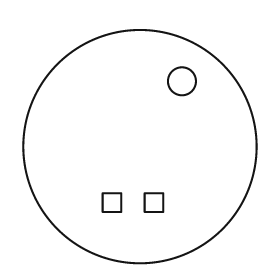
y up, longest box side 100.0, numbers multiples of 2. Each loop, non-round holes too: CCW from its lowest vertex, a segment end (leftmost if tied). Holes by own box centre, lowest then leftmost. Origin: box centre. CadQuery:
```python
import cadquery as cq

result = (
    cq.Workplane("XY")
    .moveTo(0.0, 0.0)
    .circle(50.0)
    .moveTo(-16.0, -28.0)
    .lineTo(-8.0, -28.0)
    .lineTo(-8.0, -20.0)
    .lineTo(-16.0, -20.0)
    .close()
    .moveTo(2.0, -28.0)
    .lineTo(10.0, -28.0)
    .lineTo(10.0, -20.0)
    .lineTo(2.0, -20.0)
    .close()
    .moveTo(18.0, 28.0)
    .circle(6.0)
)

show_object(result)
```